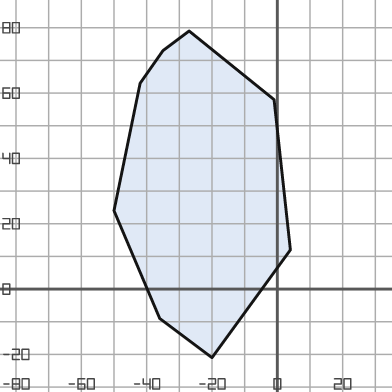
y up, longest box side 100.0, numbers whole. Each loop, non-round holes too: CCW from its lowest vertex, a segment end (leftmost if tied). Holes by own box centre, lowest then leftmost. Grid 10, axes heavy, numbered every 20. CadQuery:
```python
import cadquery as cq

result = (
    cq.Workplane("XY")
    .moveTo(-20.0, -21.0)
    .lineTo(4.0, 12.0)
    .lineTo(-1.0, 58.0)
    .lineTo(-27.0, 79.0)
    .lineTo(-35.0, 73.0)
    .lineTo(-42.0, 63.0)
    .lineTo(-50.0, 24.0)
    .lineTo(-36.0, -9.0)
    .close()
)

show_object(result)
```